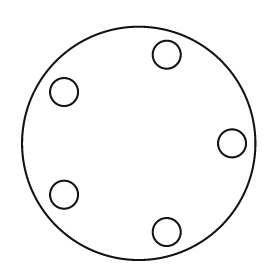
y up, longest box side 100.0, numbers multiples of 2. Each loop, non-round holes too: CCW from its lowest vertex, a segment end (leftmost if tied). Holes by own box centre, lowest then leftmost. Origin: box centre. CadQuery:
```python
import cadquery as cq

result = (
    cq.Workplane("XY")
    .moveTo(0.0, 0.0)
    .circle(50.0)
    .moveTo(12.0, -38.0)
    .circle(6.0)
    .moveTo(-32.0, -22.0)
    .circle(6.0)
    .moveTo(40.0, 0.0)
    .circle(6.0)
    .moveTo(-32.0, 22.0)
    .circle(6.0)
    .moveTo(12.0, 38.0)
    .circle(6.0)
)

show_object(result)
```